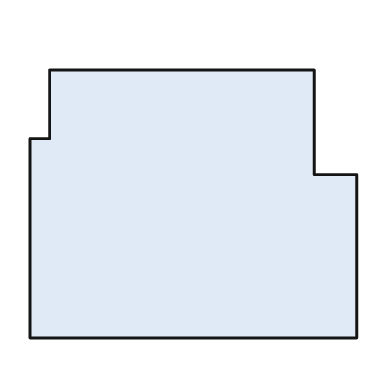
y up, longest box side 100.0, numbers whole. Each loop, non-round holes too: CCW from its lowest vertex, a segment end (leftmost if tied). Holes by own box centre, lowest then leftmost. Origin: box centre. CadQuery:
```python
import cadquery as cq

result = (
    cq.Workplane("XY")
    .moveTo(-50.0, -41.0)
    .lineTo(50.0, -41.0)
    .lineTo(50.0, 9.0)
    .lineTo(37.0, 9.0)
    .lineTo(37.0, 41.0)
    .lineTo(-44.0, 41.0)
    .lineTo(-44.0, 20.0)
    .lineTo(-50.0, 20.0)
    .close()
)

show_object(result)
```